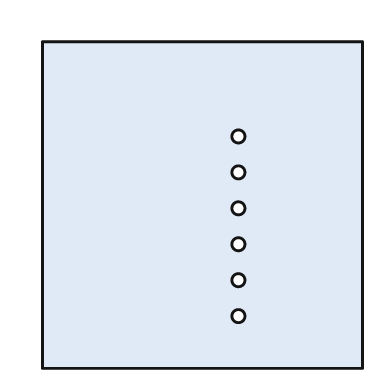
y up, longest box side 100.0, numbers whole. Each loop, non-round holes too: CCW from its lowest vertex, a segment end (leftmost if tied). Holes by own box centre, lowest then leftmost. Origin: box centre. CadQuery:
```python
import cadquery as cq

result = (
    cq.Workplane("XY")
    .moveTo(-49.0, -50.0)
    .lineTo(49.0, -50.0)
    .lineTo(49.0, 50.0)
    .lineTo(-49.0, 50.0)
    .close()
    .moveTo(11.0, -34.0)
    .circle(2.0)
    .moveTo(11.0, -23.0)
    .circle(2.0)
    .moveTo(11.0, -12.0)
    .circle(2.0)
    .moveTo(11.0, -1.0)
    .circle(2.0)
    .moveTo(11.0, 10.0)
    .circle(2.0)
    .moveTo(11.0, 21.0)
    .circle(2.0)
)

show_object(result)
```